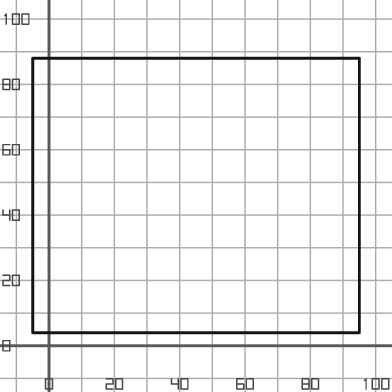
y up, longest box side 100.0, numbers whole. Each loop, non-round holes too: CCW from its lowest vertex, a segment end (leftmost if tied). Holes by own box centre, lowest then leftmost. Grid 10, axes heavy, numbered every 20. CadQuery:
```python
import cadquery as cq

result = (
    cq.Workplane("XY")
    .moveTo(-5.0, 4.0)
    .lineTo(95.0, 4.0)
    .lineTo(95.0, 88.0)
    .lineTo(-5.0, 88.0)
    .close()
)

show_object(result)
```